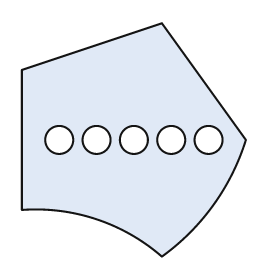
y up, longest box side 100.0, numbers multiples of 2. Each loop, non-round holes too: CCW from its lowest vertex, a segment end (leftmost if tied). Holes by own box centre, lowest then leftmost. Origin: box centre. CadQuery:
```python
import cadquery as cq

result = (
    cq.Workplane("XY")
    .moveTo(12.0, -50.0)
    .threePointArc((34.0, -28.0), (48.0, 0.0))
    .lineTo(12.0, 50.0)
    .lineTo(-48.0, 30.0)
    .lineTo(-48.0, -30.0)
    .threePointArc((-16.0, -34.0), (12.0, -50.0))
    .close()
    .moveTo(-32.0, 0.0)
    .circle(6.0)
    .moveTo(-16.0, 0.0)
    .circle(6.0)
    .moveTo(0.0, 0.0)
    .circle(6.0)
    .moveTo(16.0, 0.0)
    .circle(6.0)
    .moveTo(32.0, 0.0)
    .circle(6.0)
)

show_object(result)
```